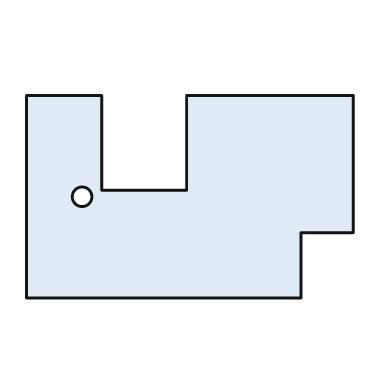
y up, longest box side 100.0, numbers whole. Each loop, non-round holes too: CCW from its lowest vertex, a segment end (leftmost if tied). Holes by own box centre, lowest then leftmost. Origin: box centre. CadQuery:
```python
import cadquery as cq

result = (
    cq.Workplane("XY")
    .moveTo(-50.0, -31.0)
    .lineTo(34.0, -31.0)
    .lineTo(34.0, -11.0)
    .lineTo(50.0, -11.0)
    .lineTo(50.0, 31.0)
    .lineTo(-1.0, 31.0)
    .lineTo(-1.0, 2.0)
    .lineTo(-27.0, 2.0)
    .lineTo(-27.0, 31.0)
    .lineTo(-50.0, 31.0)
    .close()
    .moveTo(-33.0, 0.0)
    .circle(3.0)
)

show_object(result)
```